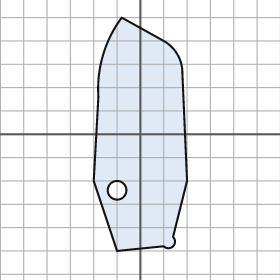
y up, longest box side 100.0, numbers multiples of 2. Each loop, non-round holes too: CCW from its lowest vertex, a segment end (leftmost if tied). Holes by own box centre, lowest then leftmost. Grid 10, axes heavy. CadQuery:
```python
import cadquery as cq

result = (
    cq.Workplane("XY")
    .moveTo(-10.0, -50.0)
    .lineTo(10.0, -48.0)
    .threePointArc((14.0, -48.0), (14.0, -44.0))
    .lineTo(20.0, -20.0)
    .lineTo(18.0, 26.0)
    .threePointArc((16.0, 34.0), (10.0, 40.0))
    .lineTo(-8.0, 50.0)
    .threePointArc((-16.0, 34.0), (-18.0, 16.0))
    .lineTo(-20.0, -20.0)
    .close()
    .moveTo(-10.0, -24.0)
    .circle(4.0)
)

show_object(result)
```